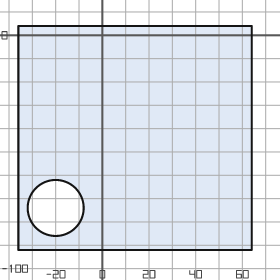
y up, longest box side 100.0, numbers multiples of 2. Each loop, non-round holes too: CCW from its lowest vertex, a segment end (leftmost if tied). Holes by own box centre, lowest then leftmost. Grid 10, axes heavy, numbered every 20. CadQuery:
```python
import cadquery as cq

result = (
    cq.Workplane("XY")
    .moveTo(-36.0, -92.0)
    .lineTo(64.0, -92.0)
    .lineTo(64.0, 4.0)
    .lineTo(-36.0, 4.0)
    .close()
    .moveTo(-20.0, -74.0)
    .circle(12.0)
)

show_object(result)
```